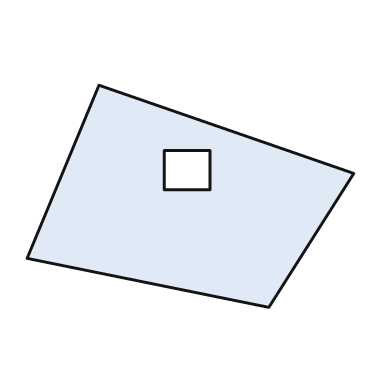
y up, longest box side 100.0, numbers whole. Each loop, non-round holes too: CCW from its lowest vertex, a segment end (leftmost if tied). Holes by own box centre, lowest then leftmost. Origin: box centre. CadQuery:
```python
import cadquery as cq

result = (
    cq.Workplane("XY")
    .moveTo(24.0, -34.0)
    .lineTo(50.0, 7.0)
    .lineTo(-28.0, 34.0)
    .lineTo(-50.0, -19.0)
    .close()
    .moveTo(-8.0, 2.0)
    .lineTo(6.0, 2.0)
    .lineTo(6.0, 14.0)
    .lineTo(-8.0, 14.0)
    .close()
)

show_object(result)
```